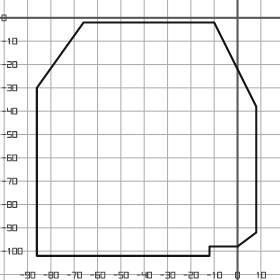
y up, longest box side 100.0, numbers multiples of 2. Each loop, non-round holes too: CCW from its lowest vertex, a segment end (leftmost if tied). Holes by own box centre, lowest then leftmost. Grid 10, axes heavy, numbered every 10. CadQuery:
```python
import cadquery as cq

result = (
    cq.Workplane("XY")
    .moveTo(-86.0, -102.0)
    .lineTo(-12.0, -102.0)
    .lineTo(-12.0, -98.0)
    .lineTo(0.0, -98.0)
    .lineTo(8.0, -92.0)
    .lineTo(8.0, -38.0)
    .lineTo(-10.0, -2.0)
    .lineTo(-66.0, -2.0)
    .lineTo(-86.0, -30.0)
    .close()
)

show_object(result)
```